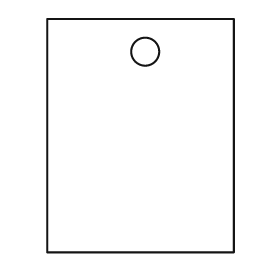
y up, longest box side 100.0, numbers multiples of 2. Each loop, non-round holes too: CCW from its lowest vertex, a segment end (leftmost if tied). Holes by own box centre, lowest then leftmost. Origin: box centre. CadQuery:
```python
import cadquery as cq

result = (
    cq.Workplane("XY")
    .moveTo(-40.0, -50.0)
    .lineTo(40.0, -50.0)
    .lineTo(40.0, 50.0)
    .lineTo(-40.0, 50.0)
    .close()
    .moveTo(2.0, 36.0)
    .circle(6.0)
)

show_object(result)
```